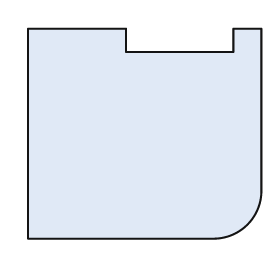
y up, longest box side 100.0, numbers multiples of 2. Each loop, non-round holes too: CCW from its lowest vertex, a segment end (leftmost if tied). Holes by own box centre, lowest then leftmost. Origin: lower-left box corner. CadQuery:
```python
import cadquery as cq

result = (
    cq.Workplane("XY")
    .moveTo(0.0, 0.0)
    .lineTo(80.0, 0.0)
    .threePointArc((94.0, 6.0), (100.0, 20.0))
    .lineTo(100.0, 90.0)
    .lineTo(88.0, 90.0)
    .lineTo(88.0, 80.0)
    .lineTo(42.0, 80.0)
    .lineTo(42.0, 90.0)
    .lineTo(0.0, 90.0)
    .close()
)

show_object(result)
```